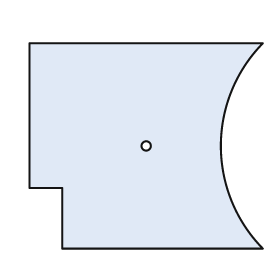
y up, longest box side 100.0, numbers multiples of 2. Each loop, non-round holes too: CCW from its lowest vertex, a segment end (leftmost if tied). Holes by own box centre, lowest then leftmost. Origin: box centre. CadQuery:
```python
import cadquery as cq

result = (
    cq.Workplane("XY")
    .moveTo(-36.0, -44.0)
    .lineTo(50.0, -44.0)
    .threePointArc((32.0, 0.0), (50.0, 44.0))
    .lineTo(-50.0, 44.0)
    .lineTo(-50.0, -18.0)
    .lineTo(-36.0, -18.0)
    .close()
    .moveTo(0.0, 0.0)
    .circle(2.0)
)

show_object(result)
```